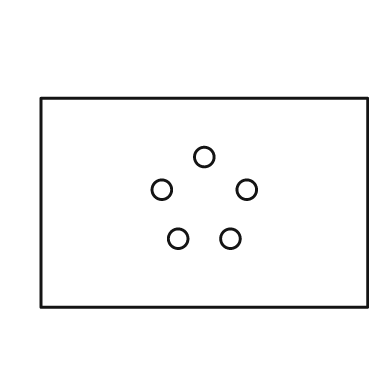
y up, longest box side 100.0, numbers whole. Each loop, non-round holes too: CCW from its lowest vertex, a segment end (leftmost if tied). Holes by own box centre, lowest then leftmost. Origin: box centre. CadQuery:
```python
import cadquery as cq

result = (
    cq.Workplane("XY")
    .moveTo(-50.0, -32.0)
    .lineTo(50.0, -32.0)
    .lineTo(50.0, 32.0)
    .lineTo(-50.0, 32.0)
    .close()
    .moveTo(-8.0, -11.0)
    .circle(3.0)
    .moveTo(8.0, -11.0)
    .circle(3.0)
    .moveTo(-13.0, 4.0)
    .circle(3.0)
    .moveTo(13.0, 4.0)
    .circle(3.0)
    .moveTo(0.0, 14.0)
    .circle(3.0)
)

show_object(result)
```